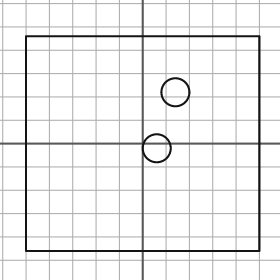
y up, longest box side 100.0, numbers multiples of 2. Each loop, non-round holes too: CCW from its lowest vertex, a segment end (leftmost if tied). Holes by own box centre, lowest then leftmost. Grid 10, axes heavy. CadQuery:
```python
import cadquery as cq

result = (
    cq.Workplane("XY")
    .moveTo(-50.0, -46.0)
    .lineTo(50.0, -46.0)
    .lineTo(50.0, 46.0)
    .lineTo(-50.0, 46.0)
    .close()
    .moveTo(6.0, -2.0)
    .circle(6.0)
    .moveTo(14.0, 22.0)
    .circle(6.0)
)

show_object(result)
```